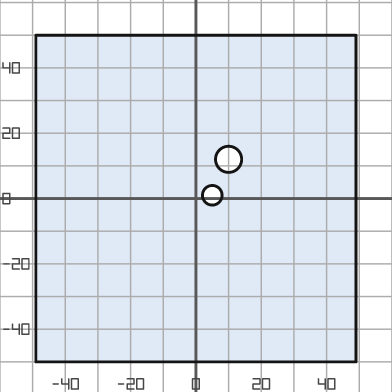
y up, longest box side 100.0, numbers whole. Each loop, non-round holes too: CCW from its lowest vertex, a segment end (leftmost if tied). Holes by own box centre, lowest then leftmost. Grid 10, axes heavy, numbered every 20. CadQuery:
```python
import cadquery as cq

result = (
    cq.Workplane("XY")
    .moveTo(-49.0, -50.0)
    .lineTo(49.0, -50.0)
    .lineTo(49.0, 50.0)
    .lineTo(-49.0, 50.0)
    .close()
    .moveTo(5.0, 1.0)
    .circle(3.0)
    .moveTo(10.0, 12.0)
    .circle(4.0)
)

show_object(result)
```